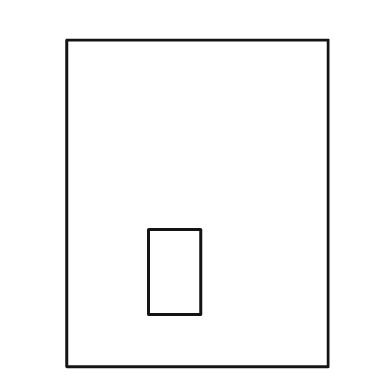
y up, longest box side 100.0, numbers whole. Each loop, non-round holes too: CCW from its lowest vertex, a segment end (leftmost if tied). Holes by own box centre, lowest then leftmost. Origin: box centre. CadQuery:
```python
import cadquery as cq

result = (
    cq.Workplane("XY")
    .moveTo(-40.0, -50.0)
    .lineTo(40.0, -50.0)
    .lineTo(40.0, 50.0)
    .lineTo(-40.0, 50.0)
    .close()
    .moveTo(-15.0, -34.0)
    .lineTo(1.0, -34.0)
    .lineTo(1.0, -8.0)
    .lineTo(-15.0, -8.0)
    .close()
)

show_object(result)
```